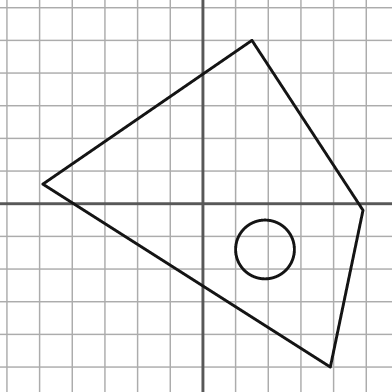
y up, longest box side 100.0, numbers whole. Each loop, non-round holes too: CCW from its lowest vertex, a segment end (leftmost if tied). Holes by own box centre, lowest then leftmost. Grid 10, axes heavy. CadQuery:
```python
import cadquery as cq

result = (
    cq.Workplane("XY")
    .moveTo(39.0, -50.0)
    .lineTo(49.0, -2.0)
    .lineTo(15.0, 50.0)
    .lineTo(-49.0, 6.0)
    .close()
    .moveTo(19.0, -14.0)
    .circle(9.0)
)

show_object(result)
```